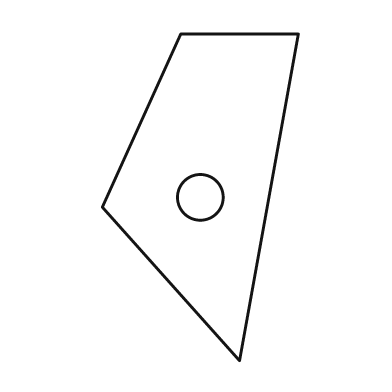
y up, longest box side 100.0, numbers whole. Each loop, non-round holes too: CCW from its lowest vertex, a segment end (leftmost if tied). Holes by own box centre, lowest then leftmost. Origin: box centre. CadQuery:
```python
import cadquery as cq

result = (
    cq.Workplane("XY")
    .moveTo(12.0, -50.0)
    .lineTo(30.0, 50.0)
    .lineTo(-6.0, 50.0)
    .lineTo(-30.0, -3.0)
    .close()
    .moveTo(0.0, 0.0)
    .circle(7.0)
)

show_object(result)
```